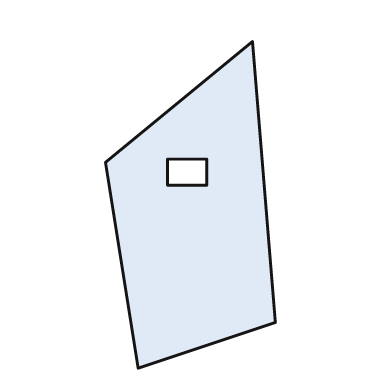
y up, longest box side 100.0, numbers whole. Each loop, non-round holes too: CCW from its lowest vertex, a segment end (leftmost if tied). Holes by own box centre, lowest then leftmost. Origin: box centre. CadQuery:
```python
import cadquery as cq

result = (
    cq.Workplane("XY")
    .moveTo(-16.0, -50.0)
    .lineTo(26.0, -36.0)
    .lineTo(19.0, 50.0)
    .lineTo(-26.0, 13.0)
    .close()
    .moveTo(-7.0, 6.0)
    .lineTo(5.0, 6.0)
    .lineTo(5.0, 14.0)
    .lineTo(-7.0, 14.0)
    .close()
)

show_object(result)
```